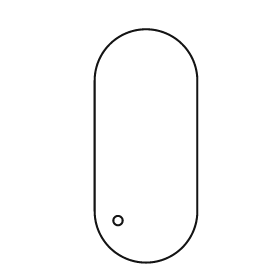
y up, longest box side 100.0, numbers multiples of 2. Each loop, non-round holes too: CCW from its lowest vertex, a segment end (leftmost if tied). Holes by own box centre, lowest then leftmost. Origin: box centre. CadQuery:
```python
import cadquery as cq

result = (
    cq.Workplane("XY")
    .moveTo(-22.0, -28.0)
    .threePointArc((0.0, -50.0), (22.0, -28.0))
    .lineTo(22.0, 28.0)
    .threePointArc((0.0, 50.0), (-22.0, 28.0))
    .close()
    .moveTo(-12.0, -32.0)
    .circle(2.0)
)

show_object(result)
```